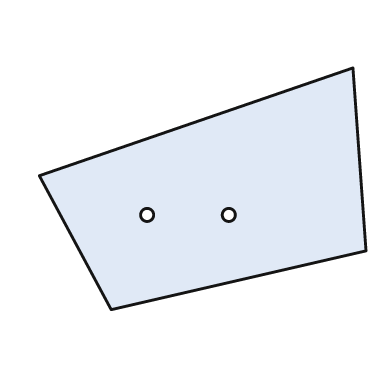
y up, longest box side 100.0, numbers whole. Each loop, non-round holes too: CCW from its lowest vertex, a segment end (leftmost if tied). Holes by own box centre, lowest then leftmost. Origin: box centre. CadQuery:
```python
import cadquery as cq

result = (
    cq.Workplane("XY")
    .moveTo(-28.0, -37.0)
    .lineTo(50.0, -19.0)
    .lineTo(46.0, 37.0)
    .lineTo(-50.0, 4.0)
    .close()
    .moveTo(-17.0, -8.0)
    .circle(2.0)
    .moveTo(8.0, -8.0)
    .circle(2.0)
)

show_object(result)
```